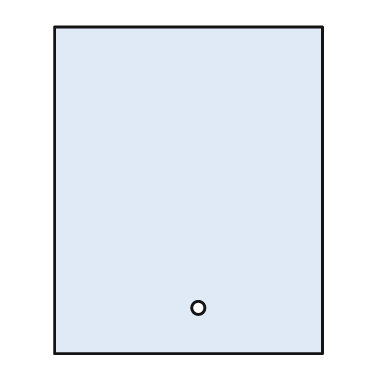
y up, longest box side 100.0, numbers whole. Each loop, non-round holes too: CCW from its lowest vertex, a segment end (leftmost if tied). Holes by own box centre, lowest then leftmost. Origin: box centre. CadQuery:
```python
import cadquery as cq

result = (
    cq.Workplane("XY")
    .moveTo(-41.0, -50.0)
    .lineTo(41.0, -50.0)
    .lineTo(41.0, 50.0)
    .lineTo(-41.0, 50.0)
    .close()
    .moveTo(3.0, -36.0)
    .circle(2.0)
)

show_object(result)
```